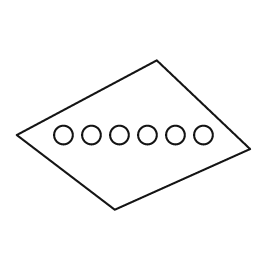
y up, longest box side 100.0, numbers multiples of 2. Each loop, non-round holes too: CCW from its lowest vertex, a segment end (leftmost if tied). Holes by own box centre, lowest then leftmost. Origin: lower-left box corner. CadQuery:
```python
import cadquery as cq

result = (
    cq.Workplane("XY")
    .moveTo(42.0, 0.0)
    .lineTo(100.0, 26.0)
    .lineTo(60.0, 64.0)
    .lineTo(0.0, 32.0)
    .close()
    .moveTo(20.0, 32.0)
    .circle(4.0)
    .moveTo(32.0, 32.0)
    .circle(4.0)
    .moveTo(44.0, 32.0)
    .circle(4.0)
    .moveTo(56.0, 32.0)
    .circle(4.0)
    .moveTo(68.0, 32.0)
    .circle(4.0)
    .moveTo(80.0, 32.0)
    .circle(4.0)
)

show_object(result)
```